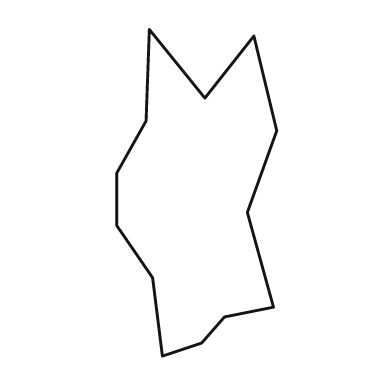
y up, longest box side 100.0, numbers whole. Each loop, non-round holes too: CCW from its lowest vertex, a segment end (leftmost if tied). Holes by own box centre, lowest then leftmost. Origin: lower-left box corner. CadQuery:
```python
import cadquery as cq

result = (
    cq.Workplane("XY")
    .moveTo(14.0, 0.0)
    .lineTo(26.0, 4.0)
    .lineTo(33.0, 12.0)
    .lineTo(48.0, 15.0)
    .lineTo(40.0, 44.0)
    .lineTo(49.0, 69.0)
    .lineTo(42.0, 98.0)
    .lineTo(27.0, 79.0)
    .lineTo(10.0, 100.0)
    .lineTo(9.0, 72.0)
    .lineTo(0.0, 56.0)
    .lineTo(0.0, 40.0)
    .lineTo(11.0, 24.0)
    .close()
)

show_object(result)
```